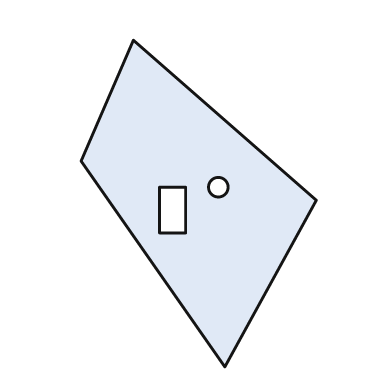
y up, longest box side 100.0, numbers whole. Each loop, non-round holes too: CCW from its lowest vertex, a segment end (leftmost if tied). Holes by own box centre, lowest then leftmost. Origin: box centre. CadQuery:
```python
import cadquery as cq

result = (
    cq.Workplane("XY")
    .moveTo(8.0, -50.0)
    .lineTo(36.0, 1.0)
    .lineTo(-20.0, 50.0)
    .lineTo(-36.0, 13.0)
    .close()
    .moveTo(-12.0, -9.0)
    .lineTo(-4.0, -9.0)
    .lineTo(-4.0, 5.0)
    .lineTo(-12.0, 5.0)
    .close()
    .moveTo(6.0, 5.0)
    .circle(3.0)
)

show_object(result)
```